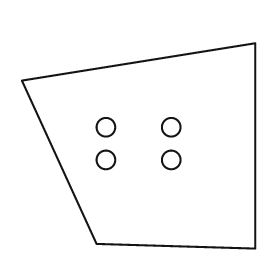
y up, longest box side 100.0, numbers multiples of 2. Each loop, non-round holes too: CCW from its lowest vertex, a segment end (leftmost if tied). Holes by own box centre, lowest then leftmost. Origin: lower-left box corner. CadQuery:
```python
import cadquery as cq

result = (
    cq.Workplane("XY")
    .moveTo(100.0, 0.0)
    .lineTo(100.0, 88.0)
    .lineTo(0.0, 72.0)
    .lineTo(32.0, 2.0)
    .close()
    .moveTo(36.0, 38.0)
    .circle(4.0)
    .moveTo(64.0, 38.0)
    .circle(4.0)
    .moveTo(36.0, 52.0)
    .circle(4.0)
    .moveTo(64.0, 52.0)
    .circle(4.0)
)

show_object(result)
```